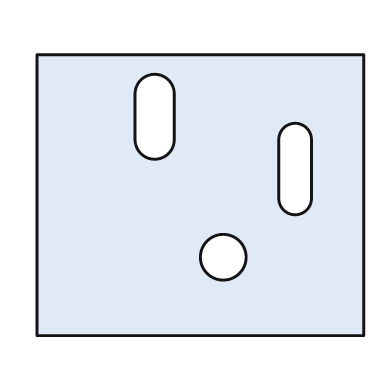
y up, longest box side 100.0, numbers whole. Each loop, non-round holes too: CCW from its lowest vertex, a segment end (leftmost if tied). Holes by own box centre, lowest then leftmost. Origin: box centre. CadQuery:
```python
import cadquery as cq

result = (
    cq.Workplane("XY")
    .moveTo(-50.0, -43.0)
    .lineTo(50.0, -43.0)
    .lineTo(50.0, 43.0)
    .lineTo(-50.0, 43.0)
    .close()
    .moveTo(7.0, -19.0)
    .circle(7.0)
    .moveTo(24.0, -1.0)
    .threePointArc((29.0, -6.0), (34.0, -1.0))
    .lineTo(34.0, 17.0)
    .threePointArc((29.0, 22.0), (24.0, 17.0))
    .close()
    .moveTo(-20.0, 17.0)
    .threePointArc((-14.0, 11.0), (-8.0, 17.0))
    .lineTo(-8.0, 31.0)
    .threePointArc((-14.0, 37.0), (-20.0, 31.0))
    .close()
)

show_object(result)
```